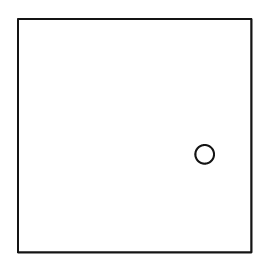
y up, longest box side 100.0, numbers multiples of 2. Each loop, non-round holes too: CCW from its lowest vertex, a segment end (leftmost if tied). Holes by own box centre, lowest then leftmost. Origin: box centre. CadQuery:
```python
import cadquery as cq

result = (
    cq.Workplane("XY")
    .moveTo(-50.0, -50.0)
    .lineTo(50.0, -50.0)
    .lineTo(50.0, 50.0)
    .lineTo(-50.0, 50.0)
    .close()
    .moveTo(30.0, -8.0)
    .circle(4.0)
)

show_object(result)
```